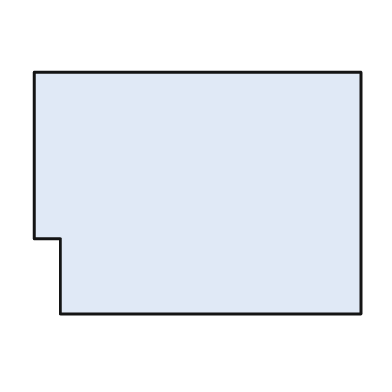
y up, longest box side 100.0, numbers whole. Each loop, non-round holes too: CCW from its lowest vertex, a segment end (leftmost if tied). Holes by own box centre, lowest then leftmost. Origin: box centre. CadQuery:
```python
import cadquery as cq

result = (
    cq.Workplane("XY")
    .moveTo(-42.0, -37.0)
    .lineTo(50.0, -37.0)
    .lineTo(50.0, 37.0)
    .lineTo(-50.0, 37.0)
    .lineTo(-50.0, -14.0)
    .lineTo(-42.0, -14.0)
    .close()
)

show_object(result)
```